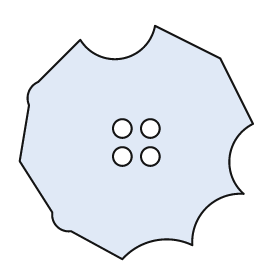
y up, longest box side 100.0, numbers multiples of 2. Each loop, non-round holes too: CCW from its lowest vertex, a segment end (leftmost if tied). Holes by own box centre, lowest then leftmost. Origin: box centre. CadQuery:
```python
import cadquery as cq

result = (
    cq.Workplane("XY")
    .moveTo(-6.0, -50.0)
    .threePointArc((8.0, -42.0), (24.0, -44.0))
    .threePointArc((30.0, -28.0), (46.0, -22.0))
    .threePointArc((40.0, -6.0), (50.0, 8.0))
    .lineTo(36.0, 36.0)
    .lineTo(8.0, 50.0)
    .threePointArc((-6.0, 36.0), (-24.0, 44.0))
    .lineTo(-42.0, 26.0)
    .threePointArc((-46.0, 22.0), (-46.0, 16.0))
    .lineTo(-50.0, -8.0)
    .lineTo(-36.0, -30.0)
    .threePointArc((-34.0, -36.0), (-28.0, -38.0))
    .close()
    .moveTo(-6.0, -6.0)
    .circle(4.0)
    .moveTo(6.0, -6.0)
    .circle(4.0)
    .moveTo(-6.0, 6.0)
    .circle(4.0)
    .moveTo(6.0, 6.0)
    .circle(4.0)
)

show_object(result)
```